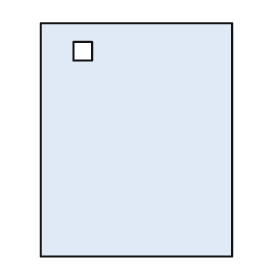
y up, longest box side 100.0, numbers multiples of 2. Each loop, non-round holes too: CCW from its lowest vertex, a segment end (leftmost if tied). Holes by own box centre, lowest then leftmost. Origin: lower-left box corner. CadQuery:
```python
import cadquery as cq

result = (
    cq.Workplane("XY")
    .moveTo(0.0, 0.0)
    .lineTo(82.0, 0.0)
    .lineTo(82.0, 100.0)
    .lineTo(0.0, 100.0)
    .close()
    .moveTo(14.0, 84.0)
    .lineTo(22.0, 84.0)
    .lineTo(22.0, 92.0)
    .lineTo(14.0, 92.0)
    .close()
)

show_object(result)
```